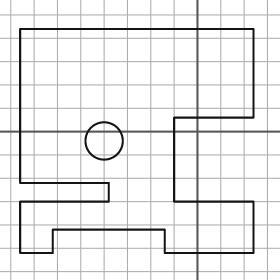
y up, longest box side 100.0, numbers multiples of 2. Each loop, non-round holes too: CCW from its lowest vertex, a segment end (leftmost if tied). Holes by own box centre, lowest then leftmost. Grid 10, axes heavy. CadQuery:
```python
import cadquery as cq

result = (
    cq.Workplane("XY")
    .moveTo(-76.0, -52.0)
    .lineTo(-62.0, -52.0)
    .lineTo(-62.0, -42.0)
    .lineTo(-14.0, -42.0)
    .lineTo(-14.0, -52.0)
    .lineTo(24.0, -52.0)
    .lineTo(24.0, -30.0)
    .lineTo(-10.0, -30.0)
    .lineTo(-10.0, 6.0)
    .lineTo(24.0, 6.0)
    .lineTo(24.0, 44.0)
    .lineTo(-76.0, 44.0)
    .lineTo(-76.0, -22.0)
    .lineTo(-38.0, -22.0)
    .lineTo(-38.0, -30.0)
    .lineTo(-76.0, -30.0)
    .close()
    .moveTo(-40.0, -4.0)
    .circle(8.0)
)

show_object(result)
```